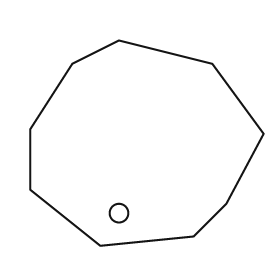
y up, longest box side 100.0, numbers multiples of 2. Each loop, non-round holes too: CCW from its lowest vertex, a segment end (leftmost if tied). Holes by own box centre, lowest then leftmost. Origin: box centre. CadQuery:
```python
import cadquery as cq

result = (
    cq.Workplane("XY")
    .moveTo(-20.0, -44.0)
    .lineTo(20.0, -40.0)
    .lineTo(34.0, -26.0)
    .lineTo(50.0, 4.0)
    .lineTo(28.0, 34.0)
    .lineTo(-12.0, 44.0)
    .lineTo(-32.0, 34.0)
    .lineTo(-50.0, 6.0)
    .lineTo(-50.0, -20.0)
    .close()
    .moveTo(-12.0, -30.0)
    .circle(4.0)
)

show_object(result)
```